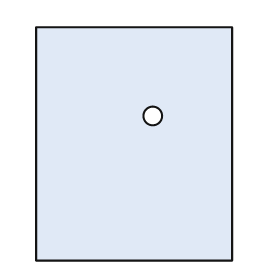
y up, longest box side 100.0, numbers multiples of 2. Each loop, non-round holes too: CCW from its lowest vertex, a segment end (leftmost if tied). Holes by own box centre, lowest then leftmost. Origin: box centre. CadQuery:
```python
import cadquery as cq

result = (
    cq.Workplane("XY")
    .moveTo(-42.0, -50.0)
    .lineTo(42.0, -50.0)
    .lineTo(42.0, 50.0)
    .lineTo(-42.0, 50.0)
    .close()
    .moveTo(8.0, 12.0)
    .circle(4.0)
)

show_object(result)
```